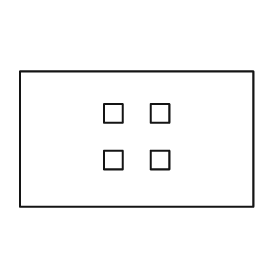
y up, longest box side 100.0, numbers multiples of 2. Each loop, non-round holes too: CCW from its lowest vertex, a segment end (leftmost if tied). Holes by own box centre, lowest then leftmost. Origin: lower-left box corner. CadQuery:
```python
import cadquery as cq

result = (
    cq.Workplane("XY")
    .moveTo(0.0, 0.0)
    .lineTo(100.0, 0.0)
    .lineTo(100.0, 58.0)
    .lineTo(0.0, 58.0)
    .close()
    .moveTo(36.0, 16.0)
    .lineTo(44.0, 16.0)
    .lineTo(44.0, 24.0)
    .lineTo(36.0, 24.0)
    .close()
    .moveTo(56.0, 16.0)
    .lineTo(64.0, 16.0)
    .lineTo(64.0, 24.0)
    .lineTo(56.0, 24.0)
    .close()
    .moveTo(36.0, 36.0)
    .lineTo(44.0, 36.0)
    .lineTo(44.0, 44.0)
    .lineTo(36.0, 44.0)
    .close()
    .moveTo(56.0, 36.0)
    .lineTo(64.0, 36.0)
    .lineTo(64.0, 44.0)
    .lineTo(56.0, 44.0)
    .close()
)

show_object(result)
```